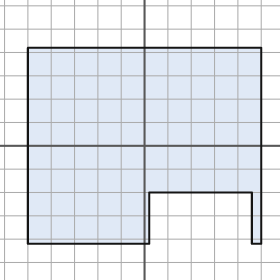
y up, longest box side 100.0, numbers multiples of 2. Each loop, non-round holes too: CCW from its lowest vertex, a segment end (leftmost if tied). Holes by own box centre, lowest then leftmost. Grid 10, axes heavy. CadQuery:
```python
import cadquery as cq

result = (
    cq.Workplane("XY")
    .moveTo(-50.0, -42.0)
    .lineTo(2.0, -42.0)
    .lineTo(2.0, -20.0)
    .lineTo(46.0, -20.0)
    .lineTo(46.0, -42.0)
    .lineTo(50.0, -42.0)
    .lineTo(50.0, 42.0)
    .lineTo(-50.0, 42.0)
    .close()
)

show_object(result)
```